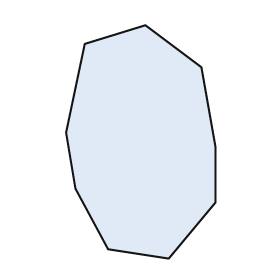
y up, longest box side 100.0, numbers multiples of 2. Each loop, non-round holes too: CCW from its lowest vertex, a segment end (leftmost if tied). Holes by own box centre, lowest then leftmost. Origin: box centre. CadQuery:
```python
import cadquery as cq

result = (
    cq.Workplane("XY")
    .moveTo(12.0, -50.0)
    .lineTo(32.0, -26.0)
    .lineTo(32.0, -2.0)
    .lineTo(26.0, 32.0)
    .lineTo(2.0, 50.0)
    .lineTo(-24.0, 42.0)
    .lineTo(-32.0, 4.0)
    .lineTo(-28.0, -20.0)
    .lineTo(-14.0, -46.0)
    .close()
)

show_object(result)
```